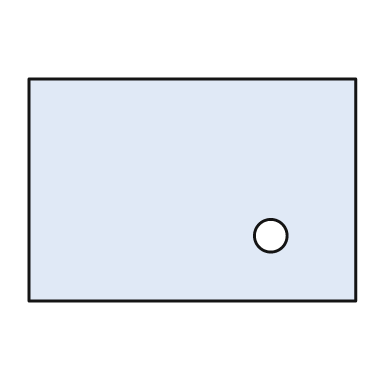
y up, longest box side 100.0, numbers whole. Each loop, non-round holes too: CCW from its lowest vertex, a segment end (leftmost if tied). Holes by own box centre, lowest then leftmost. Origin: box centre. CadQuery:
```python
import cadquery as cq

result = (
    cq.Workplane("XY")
    .moveTo(-50.0, -34.0)
    .lineTo(50.0, -34.0)
    .lineTo(50.0, 34.0)
    .lineTo(-50.0, 34.0)
    .close()
    .moveTo(24.0, -14.0)
    .circle(5.0)
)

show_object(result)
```